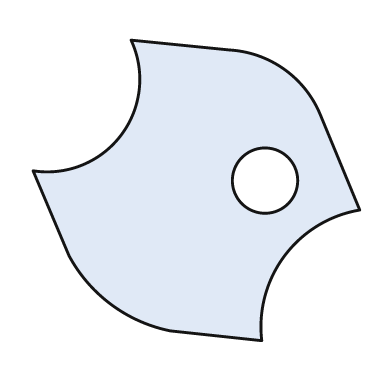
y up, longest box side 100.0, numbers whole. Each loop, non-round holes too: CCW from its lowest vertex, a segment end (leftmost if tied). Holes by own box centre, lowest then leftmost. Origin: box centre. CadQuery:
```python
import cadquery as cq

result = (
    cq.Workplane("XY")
    .moveTo(20.0, -46.0)
    .threePointArc((27.0, -20.0), (50.0, -6.0))
    .lineTo(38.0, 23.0)
    .threePointArc((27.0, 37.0), (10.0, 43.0))
    .lineTo(-20.0, 46.0)
    .threePointArc((-23.0, 17.0), (-50.0, 6.0))
    .lineTo(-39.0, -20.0)
    .threePointArc((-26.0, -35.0), (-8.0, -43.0))
    .close()
    .moveTo(21.0, 3.0)
    .circle(10.0)
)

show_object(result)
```